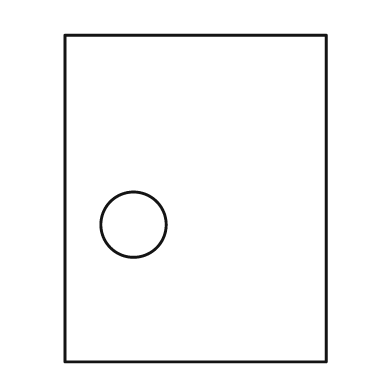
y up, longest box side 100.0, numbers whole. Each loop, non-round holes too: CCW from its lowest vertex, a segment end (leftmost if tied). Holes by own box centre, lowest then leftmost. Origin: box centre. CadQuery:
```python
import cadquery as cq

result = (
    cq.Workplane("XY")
    .moveTo(-40.0, -50.0)
    .lineTo(40.0, -50.0)
    .lineTo(40.0, 50.0)
    .lineTo(-40.0, 50.0)
    .close()
    .moveTo(-19.0, -8.0)
    .circle(10.0)
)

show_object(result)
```